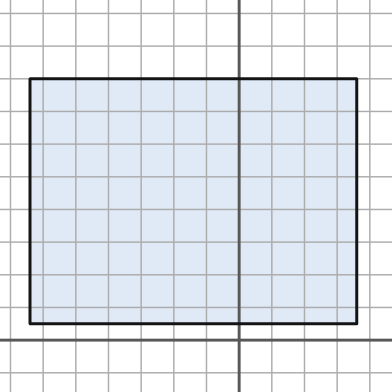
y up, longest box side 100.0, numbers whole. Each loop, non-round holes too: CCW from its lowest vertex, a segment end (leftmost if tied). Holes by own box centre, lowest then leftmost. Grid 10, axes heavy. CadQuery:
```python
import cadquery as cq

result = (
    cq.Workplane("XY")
    .moveTo(-64.0, 5.0)
    .lineTo(36.0, 5.0)
    .lineTo(36.0, 80.0)
    .lineTo(-64.0, 80.0)
    .close()
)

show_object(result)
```